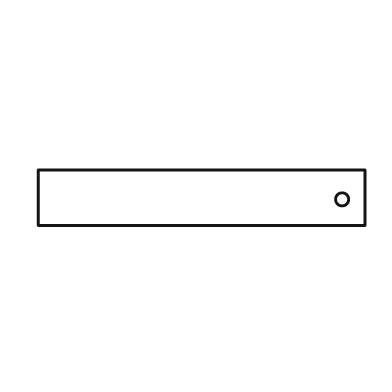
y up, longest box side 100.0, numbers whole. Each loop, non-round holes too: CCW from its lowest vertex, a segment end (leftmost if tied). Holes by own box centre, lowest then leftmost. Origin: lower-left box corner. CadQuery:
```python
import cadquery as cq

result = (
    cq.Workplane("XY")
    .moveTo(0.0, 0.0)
    .lineTo(100.0, 0.0)
    .lineTo(100.0, 17.0)
    .lineTo(0.0, 17.0)
    .close()
    .moveTo(93.0, 8.0)
    .circle(2.0)
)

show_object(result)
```